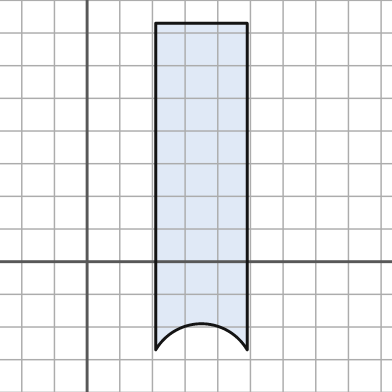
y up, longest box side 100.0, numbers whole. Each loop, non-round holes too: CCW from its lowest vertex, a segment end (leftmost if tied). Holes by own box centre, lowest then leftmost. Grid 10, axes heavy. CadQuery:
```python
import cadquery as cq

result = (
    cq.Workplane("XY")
    .moveTo(21.0, -27.0)
    .threePointArc((35.0, -19.0), (49.0, -27.0))
    .lineTo(49.0, 73.0)
    .lineTo(21.0, 73.0)
    .close()
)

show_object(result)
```